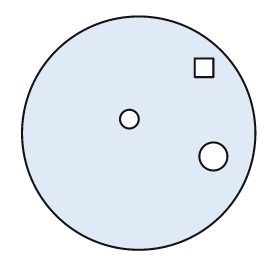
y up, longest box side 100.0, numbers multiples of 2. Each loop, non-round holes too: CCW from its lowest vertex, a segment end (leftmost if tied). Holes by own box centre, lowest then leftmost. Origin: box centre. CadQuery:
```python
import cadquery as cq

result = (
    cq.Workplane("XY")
    .moveTo(0.0, 0.0)
    .circle(50.0)
    .moveTo(32.0, -10.0)
    .circle(6.0)
    .moveTo(-4.0, 6.0)
    .circle(4.0)
    .moveTo(24.0, 24.0)
    .lineTo(32.0, 24.0)
    .lineTo(32.0, 32.0)
    .lineTo(24.0, 32.0)
    .close()
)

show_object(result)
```